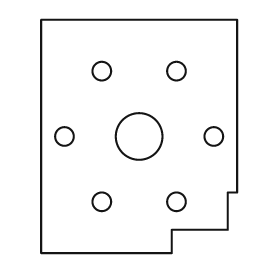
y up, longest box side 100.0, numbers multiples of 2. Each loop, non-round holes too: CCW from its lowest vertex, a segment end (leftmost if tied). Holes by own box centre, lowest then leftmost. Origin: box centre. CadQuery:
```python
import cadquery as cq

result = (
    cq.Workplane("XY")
    .moveTo(-42.0, -50.0)
    .lineTo(14.0, -50.0)
    .lineTo(14.0, -40.0)
    .lineTo(38.0, -40.0)
    .lineTo(38.0, -24.0)
    .lineTo(42.0, -24.0)
    .lineTo(42.0, 50.0)
    .lineTo(-42.0, 50.0)
    .close()
    .moveTo(-16.0, -28.0)
    .circle(4.0)
    .moveTo(16.0, -28.0)
    .circle(4.0)
    .moveTo(-32.0, 0.0)
    .circle(4.0)
    .moveTo(0.0, 0.0)
    .circle(10.0)
    .moveTo(32.0, 0.0)
    .circle(4.0)
    .moveTo(-16.0, 28.0)
    .circle(4.0)
    .moveTo(16.0, 28.0)
    .circle(4.0)
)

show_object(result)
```